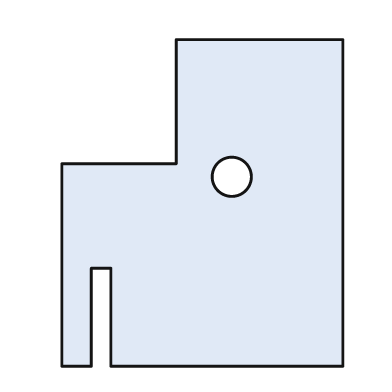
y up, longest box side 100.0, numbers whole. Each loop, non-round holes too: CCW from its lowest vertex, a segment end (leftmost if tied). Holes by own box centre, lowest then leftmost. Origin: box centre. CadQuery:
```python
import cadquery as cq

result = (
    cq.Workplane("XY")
    .moveTo(-43.0, -50.0)
    .lineTo(-34.0, -50.0)
    .lineTo(-34.0, -20.0)
    .lineTo(-28.0, -20.0)
    .lineTo(-28.0, -50.0)
    .lineTo(43.0, -50.0)
    .lineTo(43.0, 50.0)
    .lineTo(-8.0, 50.0)
    .lineTo(-8.0, 12.0)
    .lineTo(-43.0, 12.0)
    .close()
    .moveTo(9.0, 8.0)
    .circle(6.0)
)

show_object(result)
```